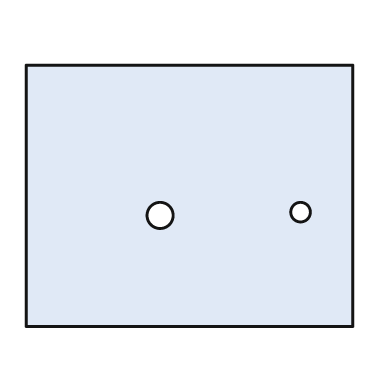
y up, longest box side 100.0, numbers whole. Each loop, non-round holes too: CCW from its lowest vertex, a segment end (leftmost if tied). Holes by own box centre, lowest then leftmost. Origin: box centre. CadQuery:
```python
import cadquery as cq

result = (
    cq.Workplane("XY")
    .moveTo(-50.0, -40.0)
    .lineTo(50.0, -40.0)
    .lineTo(50.0, 40.0)
    .lineTo(-50.0, 40.0)
    .close()
    .moveTo(-9.0, -6.0)
    .circle(4.0)
    .moveTo(34.0, -5.0)
    .circle(3.0)
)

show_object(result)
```